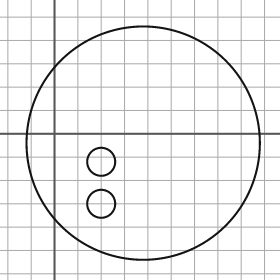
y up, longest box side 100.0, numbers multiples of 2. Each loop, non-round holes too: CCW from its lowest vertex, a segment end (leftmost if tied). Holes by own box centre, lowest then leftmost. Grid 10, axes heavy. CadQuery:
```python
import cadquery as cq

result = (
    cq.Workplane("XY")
    .moveTo(38.0, -4.0)
    .circle(50.0)
    .moveTo(20.0, -30.0)
    .circle(6.0)
    .moveTo(20.0, -12.0)
    .circle(6.0)
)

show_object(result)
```